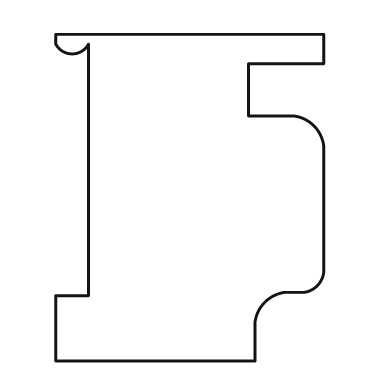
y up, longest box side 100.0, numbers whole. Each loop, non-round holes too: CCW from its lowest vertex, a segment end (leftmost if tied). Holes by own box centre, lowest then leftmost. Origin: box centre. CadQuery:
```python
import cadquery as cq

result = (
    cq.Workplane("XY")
    .moveTo(-41.0, -50.0)
    .lineTo(20.0, -50.0)
    .lineTo(20.0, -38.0)
    .threePointArc((23.0, -32.0), (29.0, -29.0))
    .lineTo(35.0, -29.0)
    .threePointArc((39.0, -27.0), (41.0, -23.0))
    .lineTo(41.0, 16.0)
    .threePointArc((38.0, 22.0), (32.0, 25.0))
    .lineTo(18.0, 25.0)
    .lineTo(18.0, 41.0)
    .lineTo(41.0, 41.0)
    .lineTo(41.0, 50.0)
    .lineTo(-41.0, 50.0)
    .lineTo(-41.0, 47.0)
    .threePointArc((-36.0, 44.0), (-31.0, 47.0))
    .lineTo(-31.0, -30.0)
    .lineTo(-41.0, -30.0)
    .close()
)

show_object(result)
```